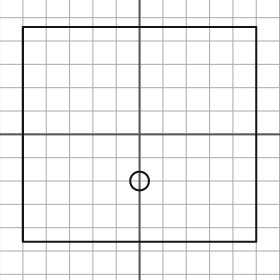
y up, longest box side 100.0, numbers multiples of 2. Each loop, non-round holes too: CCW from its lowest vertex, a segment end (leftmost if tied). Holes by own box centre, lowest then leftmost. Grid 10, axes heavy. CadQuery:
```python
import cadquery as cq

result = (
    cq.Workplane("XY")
    .moveTo(-50.0, -46.0)
    .lineTo(50.0, -46.0)
    .lineTo(50.0, 46.0)
    .lineTo(-50.0, 46.0)
    .close()
    .moveTo(0.0, -20.0)
    .circle(4.0)
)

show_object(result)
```